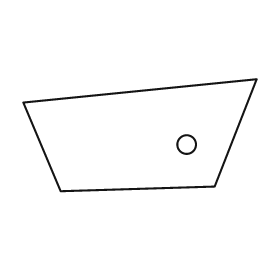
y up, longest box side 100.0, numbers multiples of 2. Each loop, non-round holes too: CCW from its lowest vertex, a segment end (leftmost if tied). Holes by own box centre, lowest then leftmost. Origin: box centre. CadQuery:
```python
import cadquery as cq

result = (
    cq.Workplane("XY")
    .moveTo(-34.0, -24.0)
    .lineTo(32.0, -22.0)
    .lineTo(50.0, 24.0)
    .lineTo(-50.0, 14.0)
    .close()
    .moveTo(20.0, -4.0)
    .circle(4.0)
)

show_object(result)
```